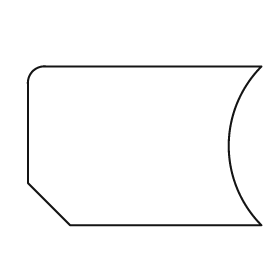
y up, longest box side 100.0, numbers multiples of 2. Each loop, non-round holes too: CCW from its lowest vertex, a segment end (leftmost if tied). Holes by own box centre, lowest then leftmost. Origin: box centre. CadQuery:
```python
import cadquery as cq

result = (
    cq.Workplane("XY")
    .moveTo(-32.0, -34.0)
    .lineTo(50.0, -34.0)
    .threePointArc((36.0, 0.0), (50.0, 34.0))
    .lineTo(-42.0, 34.0)
    .threePointArc((-48.0, 32.0), (-50.0, 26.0))
    .lineTo(-50.0, -16.0)
    .close()
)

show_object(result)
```